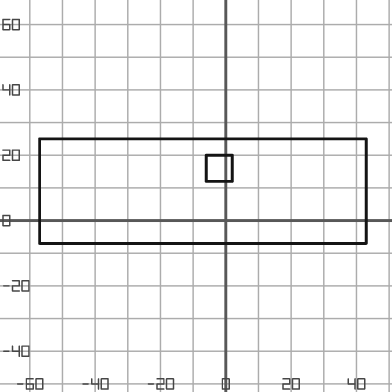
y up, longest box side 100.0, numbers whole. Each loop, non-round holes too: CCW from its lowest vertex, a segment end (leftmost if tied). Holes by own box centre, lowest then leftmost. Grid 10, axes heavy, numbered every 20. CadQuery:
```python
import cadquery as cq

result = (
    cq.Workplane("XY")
    .moveTo(-57.0, -7.0)
    .lineTo(43.0, -7.0)
    .lineTo(43.0, 25.0)
    .lineTo(-57.0, 25.0)
    .close()
    .moveTo(-6.0, 12.0)
    .lineTo(2.0, 12.0)
    .lineTo(2.0, 20.0)
    .lineTo(-6.0, 20.0)
    .close()
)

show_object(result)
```